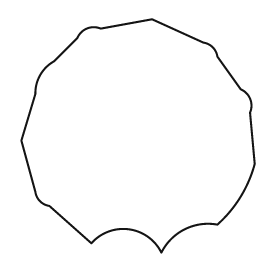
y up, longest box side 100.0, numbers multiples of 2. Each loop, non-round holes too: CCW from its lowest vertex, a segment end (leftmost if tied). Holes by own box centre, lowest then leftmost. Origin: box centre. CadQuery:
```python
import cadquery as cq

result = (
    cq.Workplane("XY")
    .moveTo(10.0, -50.0)
    .threePointArc((20.0, -40.0), (34.0, -38.0))
    .threePointArc((44.0, -26.0), (50.0, -12.0))
    .lineTo(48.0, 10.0)
    .threePointArc((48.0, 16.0), (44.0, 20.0))
    .lineTo(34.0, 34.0)
    .threePointArc((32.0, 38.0), (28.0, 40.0))
    .lineTo(6.0, 50.0)
    .lineTo(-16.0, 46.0)
    .threePointArc((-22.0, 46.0), (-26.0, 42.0))
    .lineTo(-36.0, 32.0)
    .threePointArc((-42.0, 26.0), (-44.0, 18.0))
    .lineTo(-50.0, -2.0)
    .lineTo(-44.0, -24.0)
    .threePointArc((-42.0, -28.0), (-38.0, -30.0))
    .lineTo(-20.0, -46.0)
    .threePointArc((-4.0, -40.0), (10.0, -50.0))
    .close()
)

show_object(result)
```